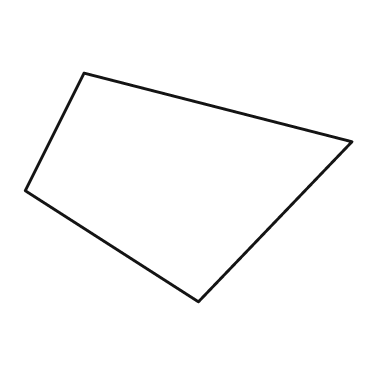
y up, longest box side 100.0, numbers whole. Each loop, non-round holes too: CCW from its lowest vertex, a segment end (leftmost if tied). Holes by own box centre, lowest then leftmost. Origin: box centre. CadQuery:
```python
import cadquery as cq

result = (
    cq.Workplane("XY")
    .moveTo(3.0, -35.0)
    .lineTo(50.0, 14.0)
    .lineTo(-32.0, 35.0)
    .lineTo(-50.0, -1.0)
    .close()
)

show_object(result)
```